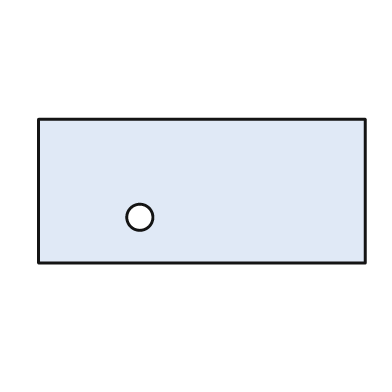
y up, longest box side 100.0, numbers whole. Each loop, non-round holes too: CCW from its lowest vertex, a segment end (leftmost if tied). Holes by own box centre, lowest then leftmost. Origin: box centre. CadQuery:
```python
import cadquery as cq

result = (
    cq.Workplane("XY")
    .moveTo(-50.0, -22.0)
    .lineTo(50.0, -22.0)
    .lineTo(50.0, 22.0)
    .lineTo(-50.0, 22.0)
    .close()
    .moveTo(-19.0, -8.0)
    .circle(4.0)
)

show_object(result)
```